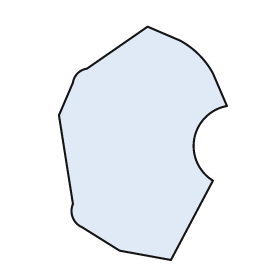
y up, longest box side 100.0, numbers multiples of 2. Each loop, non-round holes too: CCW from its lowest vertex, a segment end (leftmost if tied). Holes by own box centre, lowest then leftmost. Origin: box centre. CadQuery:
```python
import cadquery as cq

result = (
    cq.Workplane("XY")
    .moveTo(12.0, -50.0)
    .lineTo(30.0, -16.0)
    .threePointArc((22.0, 2.0), (36.0, 16.0))
    .lineTo(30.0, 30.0)
    .threePointArc((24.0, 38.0), (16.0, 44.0))
    .lineTo(2.0, 50.0)
    .lineTo(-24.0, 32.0)
    .threePointArc((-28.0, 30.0), (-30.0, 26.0))
    .lineTo(-36.0, 12.0)
    .lineTo(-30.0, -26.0)
    .threePointArc((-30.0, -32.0), (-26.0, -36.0))
    .lineTo(-10.0, -46.0)
    .close()
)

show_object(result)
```